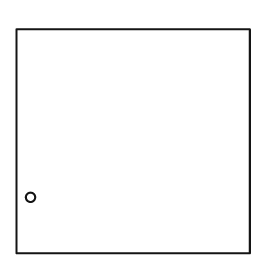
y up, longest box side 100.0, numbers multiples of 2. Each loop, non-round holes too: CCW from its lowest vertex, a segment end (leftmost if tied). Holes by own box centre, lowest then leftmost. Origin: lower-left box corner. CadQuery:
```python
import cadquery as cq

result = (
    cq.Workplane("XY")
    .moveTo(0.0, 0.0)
    .lineTo(100.0, 0.0)
    .lineTo(100.0, 96.0)
    .lineTo(0.0, 96.0)
    .close()
    .moveTo(6.0, 24.0)
    .circle(2.0)
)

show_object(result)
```